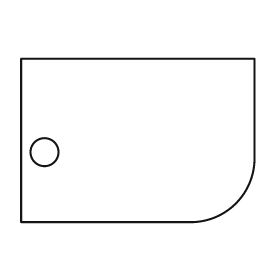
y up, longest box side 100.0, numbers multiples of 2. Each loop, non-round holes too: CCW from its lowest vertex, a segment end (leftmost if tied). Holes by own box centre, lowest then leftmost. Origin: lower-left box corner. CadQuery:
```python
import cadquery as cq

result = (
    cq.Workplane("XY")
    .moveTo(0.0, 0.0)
    .lineTo(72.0, 0.0)
    .threePointArc((92.0, 8.0), (100.0, 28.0))
    .lineTo(100.0, 70.0)
    .lineTo(0.0, 70.0)
    .close()
    .moveTo(10.0, 30.0)
    .circle(6.0)
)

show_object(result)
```